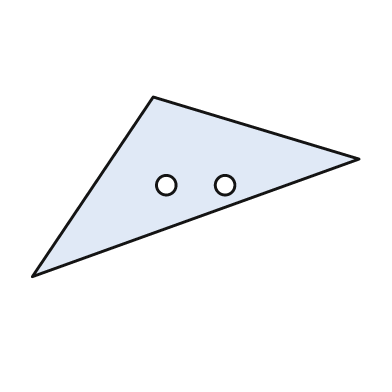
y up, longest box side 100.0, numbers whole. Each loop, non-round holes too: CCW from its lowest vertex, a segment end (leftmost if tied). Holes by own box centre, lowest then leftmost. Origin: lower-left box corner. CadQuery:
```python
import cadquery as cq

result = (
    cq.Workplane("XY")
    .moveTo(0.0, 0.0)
    .lineTo(100.0, 36.0)
    .lineTo(37.0, 55.0)
    .close()
    .moveTo(41.0, 28.0)
    .circle(3.0)
    .moveTo(59.0, 28.0)
    .circle(3.0)
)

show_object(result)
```